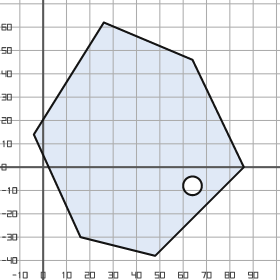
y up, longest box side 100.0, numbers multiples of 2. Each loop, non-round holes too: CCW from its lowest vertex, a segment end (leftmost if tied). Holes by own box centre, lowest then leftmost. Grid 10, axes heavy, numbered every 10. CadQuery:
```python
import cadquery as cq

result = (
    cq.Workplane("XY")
    .moveTo(48.0, -38.0)
    .lineTo(86.0, 0.0)
    .lineTo(64.0, 46.0)
    .lineTo(26.0, 62.0)
    .lineTo(-4.0, 14.0)
    .lineTo(16.0, -30.0)
    .close()
    .moveTo(64.0, -8.0)
    .circle(4.0)
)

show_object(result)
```